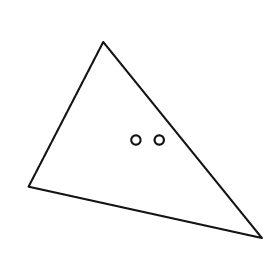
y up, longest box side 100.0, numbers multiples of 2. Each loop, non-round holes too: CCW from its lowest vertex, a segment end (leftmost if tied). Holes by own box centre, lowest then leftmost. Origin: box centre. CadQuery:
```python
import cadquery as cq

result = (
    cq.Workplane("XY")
    .moveTo(50.0, -42.0)
    .lineTo(-18.0, 42.0)
    .lineTo(-50.0, -20.0)
    .close()
    .moveTo(-4.0, 0.0)
    .circle(2.0)
    .moveTo(6.0, 0.0)
    .circle(2.0)
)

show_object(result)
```